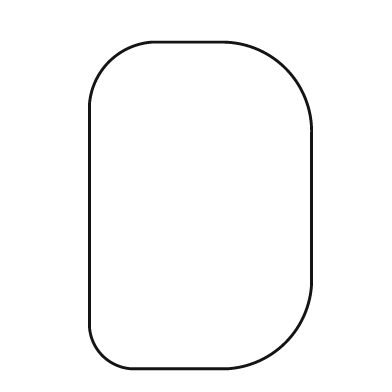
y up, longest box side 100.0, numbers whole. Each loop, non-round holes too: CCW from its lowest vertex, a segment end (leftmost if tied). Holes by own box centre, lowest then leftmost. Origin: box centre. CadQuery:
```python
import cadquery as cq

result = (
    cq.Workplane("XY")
    .moveTo(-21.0, -50.0)
    .lineTo(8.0, -50.0)
    .threePointArc((26.0, -42.0), (34.0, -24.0))
    .lineTo(34.0, 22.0)
    .threePointArc((26.0, 42.0), (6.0, 50.0))
    .lineTo(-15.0, 50.0)
    .threePointArc((-28.0, 44.0), (-34.0, 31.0))
    .lineTo(-34.0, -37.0)
    .threePointArc((-30.0, -46.0), (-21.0, -50.0))
    .close()
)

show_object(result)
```